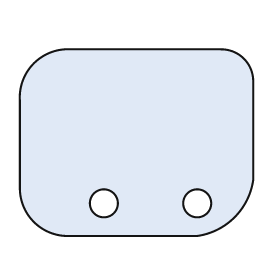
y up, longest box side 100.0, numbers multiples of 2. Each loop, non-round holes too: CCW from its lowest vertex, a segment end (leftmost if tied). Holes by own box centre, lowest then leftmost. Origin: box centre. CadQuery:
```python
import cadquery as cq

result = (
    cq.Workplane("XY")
    .moveTo(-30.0, -40.0)
    .lineTo(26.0, -40.0)
    .threePointArc((42.0, -32.0), (50.0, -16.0))
    .lineTo(50.0, 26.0)
    .threePointArc((46.0, 36.0), (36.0, 40.0))
    .lineTo(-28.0, 40.0)
    .threePointArc((-44.0, 34.0), (-50.0, 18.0))
    .lineTo(-50.0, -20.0)
    .threePointArc((-44.0, -34.0), (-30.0, -40.0))
    .close()
    .moveTo(-14.0, -26.0)
    .circle(6.0)
    .moveTo(26.0, -26.0)
    .circle(6.0)
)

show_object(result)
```